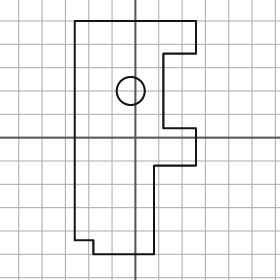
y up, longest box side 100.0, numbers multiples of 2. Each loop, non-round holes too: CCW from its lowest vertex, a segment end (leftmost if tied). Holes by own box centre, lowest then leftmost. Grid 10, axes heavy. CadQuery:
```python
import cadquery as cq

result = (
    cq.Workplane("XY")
    .moveTo(-18.0, -50.0)
    .lineTo(8.0, -50.0)
    .lineTo(8.0, -12.0)
    .lineTo(26.0, -12.0)
    .lineTo(26.0, 4.0)
    .lineTo(12.0, 4.0)
    .lineTo(12.0, 36.0)
    .lineTo(26.0, 36.0)
    .lineTo(26.0, 50.0)
    .lineTo(-26.0, 50.0)
    .lineTo(-26.0, -44.0)
    .lineTo(-18.0, -44.0)
    .close()
    .moveTo(-2.0, 20.0)
    .circle(6.0)
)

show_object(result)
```